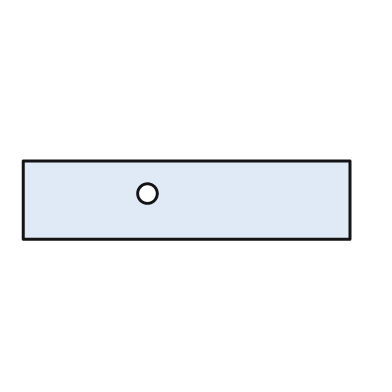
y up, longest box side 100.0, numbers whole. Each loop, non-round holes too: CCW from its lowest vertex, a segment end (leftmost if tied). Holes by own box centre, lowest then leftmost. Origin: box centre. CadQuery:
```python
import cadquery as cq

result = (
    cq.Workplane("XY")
    .moveTo(-50.0, -12.0)
    .lineTo(50.0, -12.0)
    .lineTo(50.0, 12.0)
    .lineTo(-50.0, 12.0)
    .close()
    .moveTo(-12.0, 2.0)
    .circle(3.0)
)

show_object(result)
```